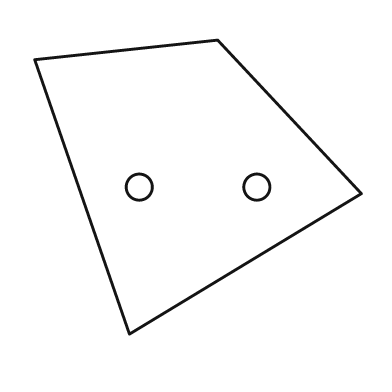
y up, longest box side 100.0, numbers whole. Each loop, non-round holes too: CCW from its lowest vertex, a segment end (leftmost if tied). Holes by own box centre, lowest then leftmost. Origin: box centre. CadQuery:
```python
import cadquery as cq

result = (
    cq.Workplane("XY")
    .moveTo(-21.0, -45.0)
    .lineTo(50.0, -2.0)
    .lineTo(6.0, 45.0)
    .lineTo(-50.0, 39.0)
    .close()
    .moveTo(-18.0, 0.0)
    .circle(4.0)
    .moveTo(18.0, 0.0)
    .circle(4.0)
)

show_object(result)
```